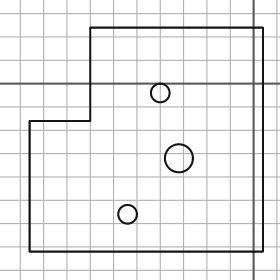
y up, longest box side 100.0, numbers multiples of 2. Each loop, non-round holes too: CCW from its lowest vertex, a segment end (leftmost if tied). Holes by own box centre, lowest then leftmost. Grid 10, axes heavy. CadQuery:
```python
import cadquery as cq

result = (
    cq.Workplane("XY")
    .moveTo(-96.0, -72.0)
    .lineTo(4.0, -72.0)
    .lineTo(4.0, 24.0)
    .lineTo(-70.0, 24.0)
    .lineTo(-70.0, -16.0)
    .lineTo(-96.0, -16.0)
    .close()
    .moveTo(-54.0, -56.0)
    .circle(4.0)
    .moveTo(-32.0, -32.0)
    .circle(6.0)
    .moveTo(-40.0, -4.0)
    .circle(4.0)
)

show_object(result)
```